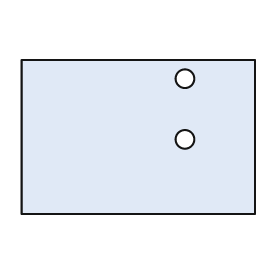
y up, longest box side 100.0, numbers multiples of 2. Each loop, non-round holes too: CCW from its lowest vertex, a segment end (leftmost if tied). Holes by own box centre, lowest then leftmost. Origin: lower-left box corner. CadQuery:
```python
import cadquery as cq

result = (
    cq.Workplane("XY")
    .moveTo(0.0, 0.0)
    .lineTo(100.0, 0.0)
    .lineTo(100.0, 66.0)
    .lineTo(0.0, 66.0)
    .close()
    .moveTo(70.0, 32.0)
    .circle(4.0)
    .moveTo(70.0, 58.0)
    .circle(4.0)
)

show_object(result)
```